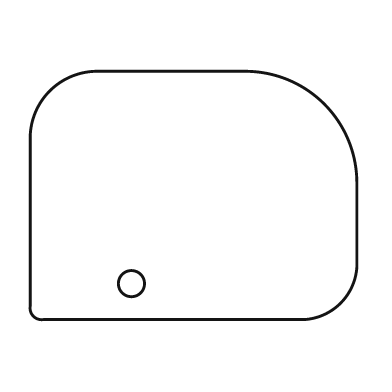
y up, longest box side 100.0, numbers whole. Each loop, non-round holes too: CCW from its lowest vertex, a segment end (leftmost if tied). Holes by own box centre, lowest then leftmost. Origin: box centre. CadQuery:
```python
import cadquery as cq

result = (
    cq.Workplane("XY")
    .moveTo(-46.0, -38.0)
    .lineTo(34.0, -38.0)
    .threePointArc((45.0, -33.0), (50.0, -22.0))
    .lineTo(50.0, 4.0)
    .threePointArc((40.0, 28.0), (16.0, 38.0))
    .lineTo(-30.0, 38.0)
    .threePointArc((-44.0, 32.0), (-50.0, 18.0))
    .lineTo(-50.0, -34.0)
    .threePointArc((-49.0, -37.0), (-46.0, -38.0))
    .close()
    .moveTo(-19.0, -27.0)
    .circle(4.0)
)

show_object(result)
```